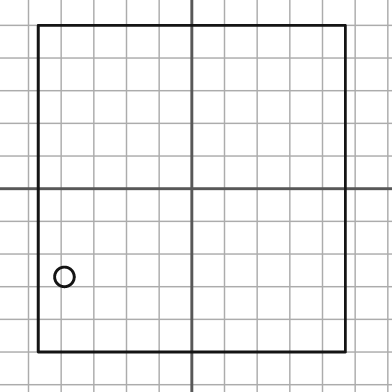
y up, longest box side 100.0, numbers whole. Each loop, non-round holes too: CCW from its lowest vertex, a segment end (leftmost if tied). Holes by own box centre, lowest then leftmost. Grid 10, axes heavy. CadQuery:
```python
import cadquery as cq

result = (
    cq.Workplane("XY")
    .moveTo(-47.0, -50.0)
    .lineTo(47.0, -50.0)
    .lineTo(47.0, 50.0)
    .lineTo(-47.0, 50.0)
    .close()
    .moveTo(-39.0, -27.0)
    .circle(3.0)
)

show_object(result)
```